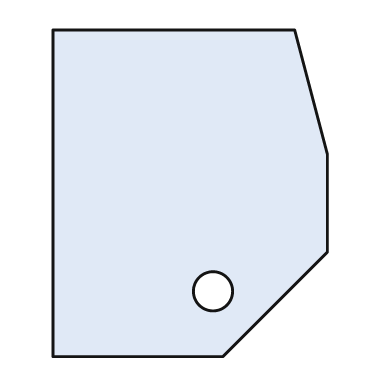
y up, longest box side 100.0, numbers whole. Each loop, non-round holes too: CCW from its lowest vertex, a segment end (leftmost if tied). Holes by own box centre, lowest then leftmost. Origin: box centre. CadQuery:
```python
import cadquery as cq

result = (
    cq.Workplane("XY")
    .moveTo(-42.0, -50.0)
    .lineTo(10.0, -50.0)
    .lineTo(42.0, -18.0)
    .lineTo(42.0, 12.0)
    .lineTo(32.0, 50.0)
    .lineTo(-42.0, 50.0)
    .close()
    .moveTo(7.0, -30.0)
    .circle(6.0)
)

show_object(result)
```